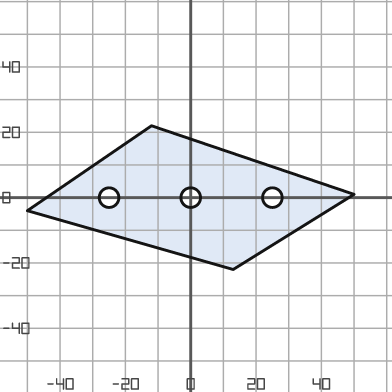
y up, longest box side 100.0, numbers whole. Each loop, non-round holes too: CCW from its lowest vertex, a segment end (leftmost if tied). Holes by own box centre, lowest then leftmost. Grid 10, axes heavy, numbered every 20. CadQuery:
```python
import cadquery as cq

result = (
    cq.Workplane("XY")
    .moveTo(13.0, -22.0)
    .lineTo(50.0, 1.0)
    .lineTo(-12.0, 22.0)
    .lineTo(-50.0, -4.0)
    .close()
    .moveTo(-25.0, 0.0)
    .circle(3.0)
    .moveTo(0.0, 0.0)
    .circle(3.0)
    .moveTo(25.0, 0.0)
    .circle(3.0)
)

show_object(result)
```